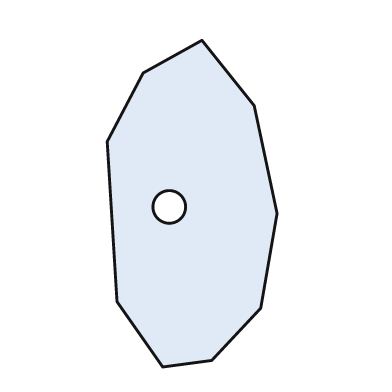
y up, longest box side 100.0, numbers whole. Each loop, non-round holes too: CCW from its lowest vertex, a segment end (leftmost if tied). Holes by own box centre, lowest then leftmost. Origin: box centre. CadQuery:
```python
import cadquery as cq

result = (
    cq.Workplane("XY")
    .moveTo(-9.0, -50.0)
    .lineTo(6.0, -48.0)
    .lineTo(21.0, -32.0)
    .lineTo(26.0, -3.0)
    .lineTo(19.0, 30.0)
    .lineTo(3.0, 50.0)
    .lineTo(-15.0, 40.0)
    .lineTo(-26.0, 19.0)
    .lineTo(-23.0, -30.0)
    .close()
    .moveTo(-7.0, -1.0)
    .circle(5.0)
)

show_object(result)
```